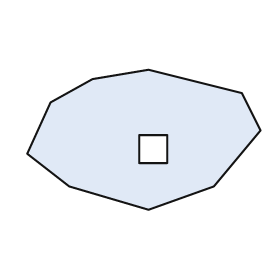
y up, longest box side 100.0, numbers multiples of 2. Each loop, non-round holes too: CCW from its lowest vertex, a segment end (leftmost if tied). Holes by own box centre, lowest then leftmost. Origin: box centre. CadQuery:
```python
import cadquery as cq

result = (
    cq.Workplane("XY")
    .moveTo(2.0, -30.0)
    .lineTo(30.0, -20.0)
    .lineTo(50.0, 4.0)
    .lineTo(42.0, 20.0)
    .lineTo(2.0, 30.0)
    .lineTo(-22.0, 26.0)
    .lineTo(-40.0, 16.0)
    .lineTo(-50.0, -6.0)
    .lineTo(-32.0, -20.0)
    .close()
    .moveTo(-2.0, -10.0)
    .lineTo(10.0, -10.0)
    .lineTo(10.0, 2.0)
    .lineTo(-2.0, 2.0)
    .close()
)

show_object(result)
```